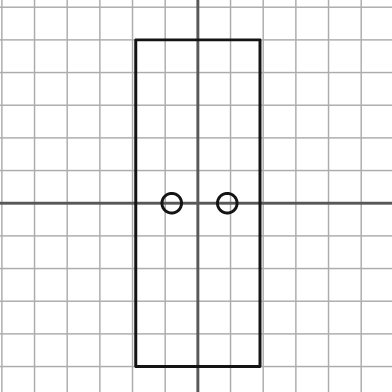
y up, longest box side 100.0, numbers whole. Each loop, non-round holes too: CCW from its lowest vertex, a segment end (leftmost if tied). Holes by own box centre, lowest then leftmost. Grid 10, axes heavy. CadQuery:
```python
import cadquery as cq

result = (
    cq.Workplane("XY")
    .moveTo(-19.0, -50.0)
    .lineTo(19.0, -50.0)
    .lineTo(19.0, 50.0)
    .lineTo(-19.0, 50.0)
    .close()
    .moveTo(-8.0, 0.0)
    .circle(3.0)
    .moveTo(9.0, 0.0)
    .circle(3.0)
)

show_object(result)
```